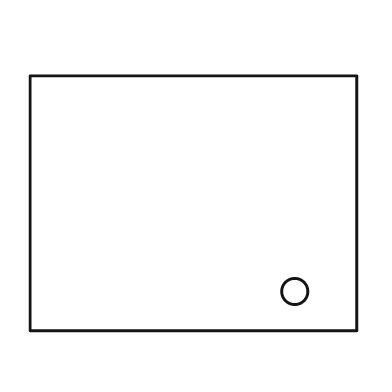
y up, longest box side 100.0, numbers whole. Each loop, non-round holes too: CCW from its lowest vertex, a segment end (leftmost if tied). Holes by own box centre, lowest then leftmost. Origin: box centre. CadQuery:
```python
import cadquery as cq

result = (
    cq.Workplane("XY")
    .moveTo(-50.0, -39.0)
    .lineTo(50.0, -39.0)
    .lineTo(50.0, 39.0)
    .lineTo(-50.0, 39.0)
    .close()
    .moveTo(31.0, -27.0)
    .circle(4.0)
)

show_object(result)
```